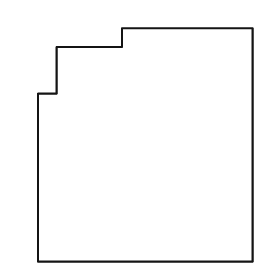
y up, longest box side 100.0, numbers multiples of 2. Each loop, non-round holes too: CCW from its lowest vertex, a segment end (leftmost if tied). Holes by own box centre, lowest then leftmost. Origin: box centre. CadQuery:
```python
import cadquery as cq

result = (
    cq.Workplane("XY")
    .moveTo(-46.0, -50.0)
    .lineTo(46.0, -50.0)
    .lineTo(46.0, 50.0)
    .lineTo(-10.0, 50.0)
    .lineTo(-10.0, 42.0)
    .lineTo(-38.0, 42.0)
    .lineTo(-38.0, 22.0)
    .lineTo(-46.0, 22.0)
    .close()
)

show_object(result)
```